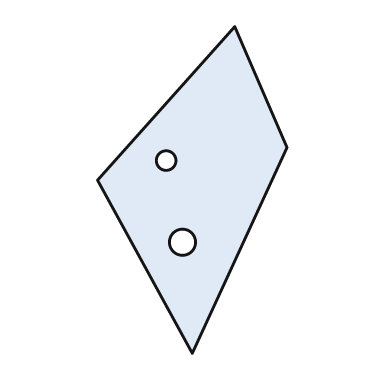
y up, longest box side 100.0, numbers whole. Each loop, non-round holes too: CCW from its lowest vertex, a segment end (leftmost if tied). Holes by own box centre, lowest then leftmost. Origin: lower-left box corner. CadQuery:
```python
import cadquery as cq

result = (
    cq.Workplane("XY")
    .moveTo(29.0, 0.0)
    .lineTo(58.0, 63.0)
    .lineTo(42.0, 100.0)
    .lineTo(0.0, 53.0)
    .close()
    .moveTo(26.0, 34.0)
    .circle(4.0)
    .moveTo(21.0, 59.0)
    .circle(3.0)
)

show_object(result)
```